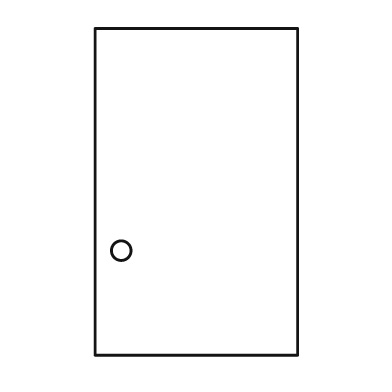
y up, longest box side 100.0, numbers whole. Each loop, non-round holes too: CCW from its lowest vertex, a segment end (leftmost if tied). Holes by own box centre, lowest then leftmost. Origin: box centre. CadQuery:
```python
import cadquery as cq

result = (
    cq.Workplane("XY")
    .moveTo(-31.0, -50.0)
    .lineTo(31.0, -50.0)
    .lineTo(31.0, 50.0)
    .lineTo(-31.0, 50.0)
    .close()
    .moveTo(-23.0, -18.0)
    .circle(3.0)
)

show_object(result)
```